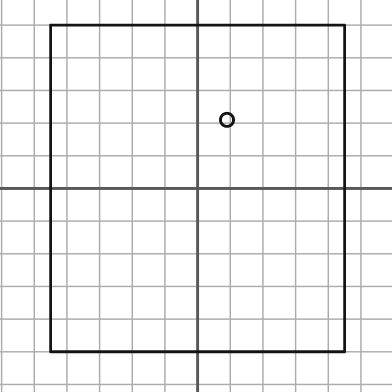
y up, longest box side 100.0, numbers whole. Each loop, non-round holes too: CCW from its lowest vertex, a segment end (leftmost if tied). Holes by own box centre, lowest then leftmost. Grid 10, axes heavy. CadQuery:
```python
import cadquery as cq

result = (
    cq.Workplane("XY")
    .moveTo(-45.0, -50.0)
    .lineTo(45.0, -50.0)
    .lineTo(45.0, 50.0)
    .lineTo(-45.0, 50.0)
    .close()
    .moveTo(9.0, 21.0)
    .circle(2.0)
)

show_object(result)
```